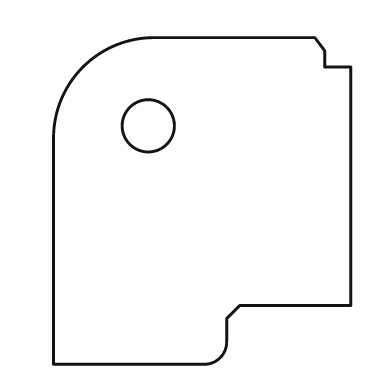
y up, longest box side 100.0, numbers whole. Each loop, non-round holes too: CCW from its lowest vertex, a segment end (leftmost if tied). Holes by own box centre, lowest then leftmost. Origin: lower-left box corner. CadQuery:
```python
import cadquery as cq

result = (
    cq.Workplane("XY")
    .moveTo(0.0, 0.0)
    .lineTo(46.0, 0.0)
    .threePointArc((51.0, 2.0), (53.0, 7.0))
    .lineTo(53.0, 14.0)
    .lineTo(57.0, 18.0)
    .lineTo(91.0, 18.0)
    .lineTo(91.0, 91.0)
    .lineTo(83.0, 91.0)
    .lineTo(83.0, 96.0)
    .lineTo(80.0, 100.0)
    .lineTo(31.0, 100.0)
    .threePointArc((9.0, 91.0), (0.0, 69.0))
    .close()
    .moveTo(29.0, 73.0)
    .circle(8.0)
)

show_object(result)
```